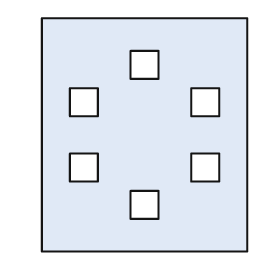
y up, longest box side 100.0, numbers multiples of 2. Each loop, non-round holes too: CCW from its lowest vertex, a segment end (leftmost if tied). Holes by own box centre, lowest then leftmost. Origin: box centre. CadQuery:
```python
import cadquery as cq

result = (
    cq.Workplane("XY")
    .moveTo(-44.0, -50.0)
    .lineTo(44.0, -50.0)
    .lineTo(44.0, 50.0)
    .lineTo(-44.0, 50.0)
    .close()
    .moveTo(-6.0, -36.0)
    .lineTo(6.0, -36.0)
    .lineTo(6.0, -24.0)
    .lineTo(-6.0, -24.0)
    .close()
    .moveTo(-32.0, -20.0)
    .lineTo(-20.0, -20.0)
    .lineTo(-20.0, -8.0)
    .lineTo(-32.0, -8.0)
    .close()
    .moveTo(20.0, -20.0)
    .lineTo(32.0, -20.0)
    .lineTo(32.0, -8.0)
    .lineTo(20.0, -8.0)
    .close()
    .moveTo(-32.0, 8.0)
    .lineTo(-20.0, 8.0)
    .lineTo(-20.0, 20.0)
    .lineTo(-32.0, 20.0)
    .close()
    .moveTo(20.0, 8.0)
    .lineTo(32.0, 8.0)
    .lineTo(32.0, 20.0)
    .lineTo(20.0, 20.0)
    .close()
    .moveTo(-6.0, 24.0)
    .lineTo(6.0, 24.0)
    .lineTo(6.0, 36.0)
    .lineTo(-6.0, 36.0)
    .close()
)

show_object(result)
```